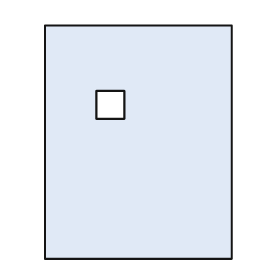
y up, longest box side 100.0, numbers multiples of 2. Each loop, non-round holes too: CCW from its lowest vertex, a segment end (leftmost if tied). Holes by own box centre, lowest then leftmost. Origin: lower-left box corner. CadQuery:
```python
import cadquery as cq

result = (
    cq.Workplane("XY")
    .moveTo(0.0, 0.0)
    .lineTo(80.0, 0.0)
    .lineTo(80.0, 100.0)
    .lineTo(0.0, 100.0)
    .close()
    .moveTo(22.0, 60.0)
    .lineTo(34.0, 60.0)
    .lineTo(34.0, 72.0)
    .lineTo(22.0, 72.0)
    .close()
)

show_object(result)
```